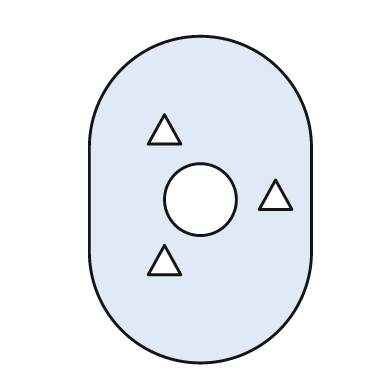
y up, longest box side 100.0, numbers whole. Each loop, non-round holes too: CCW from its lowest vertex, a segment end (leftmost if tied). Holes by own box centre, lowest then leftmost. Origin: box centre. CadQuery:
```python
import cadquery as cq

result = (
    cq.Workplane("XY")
    .moveTo(-34.0, -16.0)
    .threePointArc((0.0, -50.0), (34.0, -16.0))
    .lineTo(34.0, 16.0)
    .threePointArc((0.0, 50.0), (-34.0, 16.0))
    .close()
    .moveTo(-16.0, -23.0)
    .lineTo(-6.0, -23.0)
    .lineTo(-11.0, -14.0)
    .close()
    .moveTo(0.0, 0.0)
    .circle(11.0)
    .moveTo(18.0, -3.0)
    .lineTo(28.0, -3.0)
    .lineTo(23.0, 6.0)
    .close()
    .moveTo(-16.0, 17.0)
    .lineTo(-6.0, 17.0)
    .lineTo(-11.0, 26.0)
    .close()
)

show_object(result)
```